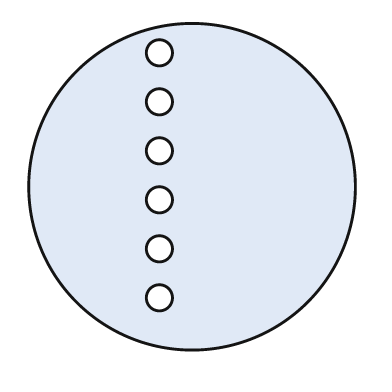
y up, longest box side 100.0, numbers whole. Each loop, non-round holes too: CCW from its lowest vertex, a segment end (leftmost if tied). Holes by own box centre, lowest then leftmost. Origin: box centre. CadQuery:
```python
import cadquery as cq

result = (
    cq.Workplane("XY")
    .moveTo(0.0, 0.0)
    .circle(50.0)
    .moveTo(-10.0, -34.0)
    .circle(4.0)
    .moveTo(-10.0, -19.0)
    .circle(4.0)
    .moveTo(-10.0, -4.0)
    .circle(4.0)
    .moveTo(-10.0, 11.0)
    .circle(4.0)
    .moveTo(-10.0, 26.0)
    .circle(4.0)
    .moveTo(-10.0, 41.0)
    .circle(4.0)
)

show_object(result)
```